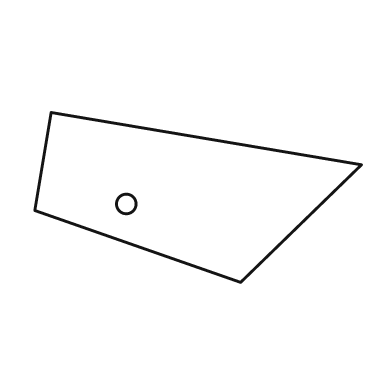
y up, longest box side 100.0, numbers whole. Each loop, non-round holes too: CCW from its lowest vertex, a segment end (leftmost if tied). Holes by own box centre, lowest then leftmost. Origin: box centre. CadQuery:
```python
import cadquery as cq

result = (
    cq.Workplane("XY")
    .moveTo(13.0, -26.0)
    .lineTo(50.0, 10.0)
    .lineTo(-45.0, 26.0)
    .lineTo(-50.0, -4.0)
    .close()
    .moveTo(-22.0, -2.0)
    .circle(3.0)
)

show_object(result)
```